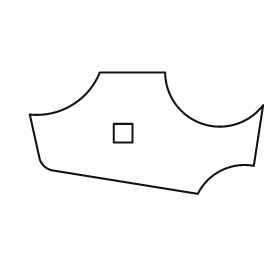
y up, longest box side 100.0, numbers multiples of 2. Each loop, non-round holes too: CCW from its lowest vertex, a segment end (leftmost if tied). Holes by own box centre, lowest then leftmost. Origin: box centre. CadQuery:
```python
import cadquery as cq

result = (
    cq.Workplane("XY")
    .moveTo(22.0, -26.0)
    .threePointArc((32.0, -16.0), (46.0, -14.0))
    .lineTo(50.0, 12.0)
    .threePointArc((24.0, 4.0), (8.0, 26.0))
    .lineTo(-20.0, 26.0)
    .threePointArc((-32.0, 12.0), (-50.0, 8.0))
    .lineTo(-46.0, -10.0)
    .threePointArc((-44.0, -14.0), (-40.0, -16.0))
    .close()
    .moveTo(-14.0, -4.0)
    .lineTo(-6.0, -4.0)
    .lineTo(-6.0, 4.0)
    .lineTo(-14.0, 4.0)
    .close()
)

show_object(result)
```